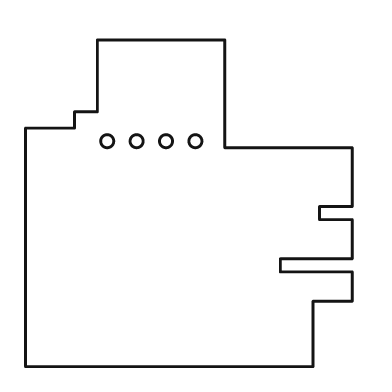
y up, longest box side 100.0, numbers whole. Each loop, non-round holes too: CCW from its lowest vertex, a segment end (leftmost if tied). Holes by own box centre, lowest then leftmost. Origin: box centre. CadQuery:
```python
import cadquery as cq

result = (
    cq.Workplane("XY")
    .moveTo(-50.0, -50.0)
    .lineTo(38.0, -50.0)
    .lineTo(38.0, -30.0)
    .lineTo(50.0, -30.0)
    .lineTo(50.0, -21.0)
    .lineTo(28.0, -21.0)
    .lineTo(28.0, -17.0)
    .lineTo(50.0, -17.0)
    .lineTo(50.0, -5.0)
    .lineTo(40.0, -5.0)
    .lineTo(40.0, -1.0)
    .lineTo(50.0, -1.0)
    .lineTo(50.0, 17.0)
    .lineTo(11.0, 17.0)
    .lineTo(11.0, 50.0)
    .lineTo(-28.0, 50.0)
    .lineTo(-28.0, 28.0)
    .lineTo(-35.0, 28.0)
    .lineTo(-35.0, 23.0)
    .lineTo(-50.0, 23.0)
    .close()
    .moveTo(-25.0, 19.0)
    .circle(2.0)
    .moveTo(-16.0, 19.0)
    .circle(2.0)
    .moveTo(-7.0, 19.0)
    .circle(2.0)
    .moveTo(2.0, 19.0)
    .circle(2.0)
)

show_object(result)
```